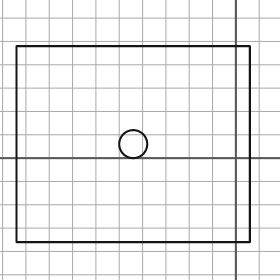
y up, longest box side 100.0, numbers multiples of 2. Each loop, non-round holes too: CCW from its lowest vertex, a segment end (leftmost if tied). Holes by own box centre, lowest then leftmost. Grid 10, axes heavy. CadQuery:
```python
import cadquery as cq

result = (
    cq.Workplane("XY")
    .moveTo(-94.0, -36.0)
    .lineTo(6.0, -36.0)
    .lineTo(6.0, 48.0)
    .lineTo(-94.0, 48.0)
    .close()
    .moveTo(-44.0, 6.0)
    .circle(6.0)
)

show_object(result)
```